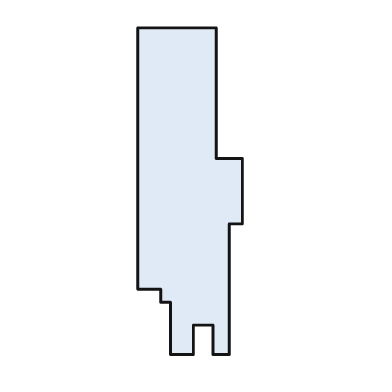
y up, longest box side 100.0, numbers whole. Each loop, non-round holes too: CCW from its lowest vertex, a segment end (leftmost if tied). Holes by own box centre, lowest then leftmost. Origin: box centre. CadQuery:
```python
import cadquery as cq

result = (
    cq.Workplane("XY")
    .moveTo(-6.0, -50.0)
    .lineTo(1.0, -50.0)
    .lineTo(1.0, -41.0)
    .lineTo(7.0, -41.0)
    .lineTo(7.0, -50.0)
    .lineTo(12.0, -50.0)
    .lineTo(12.0, -10.0)
    .lineTo(16.0, -10.0)
    .lineTo(16.0, 10.0)
    .lineTo(8.0, 10.0)
    .lineTo(8.0, 50.0)
    .lineTo(-16.0, 50.0)
    .lineTo(-16.0, -30.0)
    .lineTo(-9.0, -30.0)
    .lineTo(-9.0, -34.0)
    .lineTo(-6.0, -34.0)
    .close()
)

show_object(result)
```